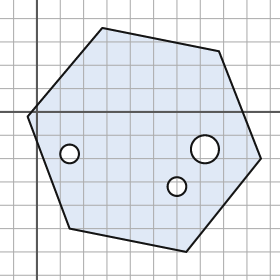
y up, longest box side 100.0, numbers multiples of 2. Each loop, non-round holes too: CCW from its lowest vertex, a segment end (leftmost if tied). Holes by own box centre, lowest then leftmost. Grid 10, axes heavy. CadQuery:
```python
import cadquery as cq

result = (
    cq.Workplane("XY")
    .moveTo(64.0, -60.0)
    .lineTo(96.0, -20.0)
    .lineTo(78.0, 26.0)
    .lineTo(28.0, 36.0)
    .lineTo(-4.0, -2.0)
    .lineTo(14.0, -50.0)
    .close()
    .moveTo(60.0, -32.0)
    .circle(4.0)
    .moveTo(14.0, -18.0)
    .circle(4.0)
    .moveTo(72.0, -16.0)
    .circle(6.0)
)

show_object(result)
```